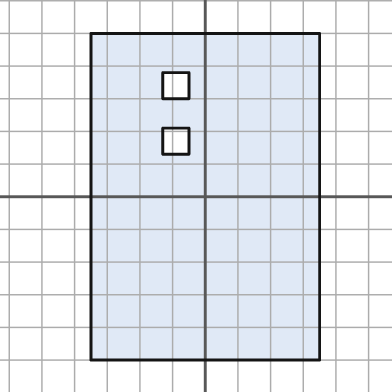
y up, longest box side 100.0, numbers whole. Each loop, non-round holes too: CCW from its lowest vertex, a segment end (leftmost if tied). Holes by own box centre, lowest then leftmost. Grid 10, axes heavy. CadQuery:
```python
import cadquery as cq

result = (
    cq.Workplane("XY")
    .moveTo(-35.0, -50.0)
    .lineTo(35.0, -50.0)
    .lineTo(35.0, 50.0)
    .lineTo(-35.0, 50.0)
    .close()
    .moveTo(-13.0, 13.0)
    .lineTo(-5.0, 13.0)
    .lineTo(-5.0, 21.0)
    .lineTo(-13.0, 21.0)
    .close()
    .moveTo(-13.0, 30.0)
    .lineTo(-5.0, 30.0)
    .lineTo(-5.0, 38.0)
    .lineTo(-13.0, 38.0)
    .close()
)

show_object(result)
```